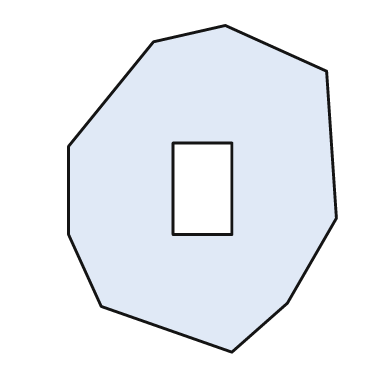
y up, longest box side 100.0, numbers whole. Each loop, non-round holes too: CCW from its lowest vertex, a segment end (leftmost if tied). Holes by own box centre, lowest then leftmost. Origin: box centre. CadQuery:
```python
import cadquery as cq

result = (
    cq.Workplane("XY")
    .moveTo(9.0, -50.0)
    .lineTo(26.0, -35.0)
    .lineTo(41.0, -9.0)
    .lineTo(38.0, 36.0)
    .lineTo(7.0, 50.0)
    .lineTo(-15.0, 45.0)
    .lineTo(-41.0, 13.0)
    .lineTo(-41.0, -14.0)
    .lineTo(-31.0, -36.0)
    .close()
    .moveTo(-9.0, -14.0)
    .lineTo(9.0, -14.0)
    .lineTo(9.0, 14.0)
    .lineTo(-9.0, 14.0)
    .close()
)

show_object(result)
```